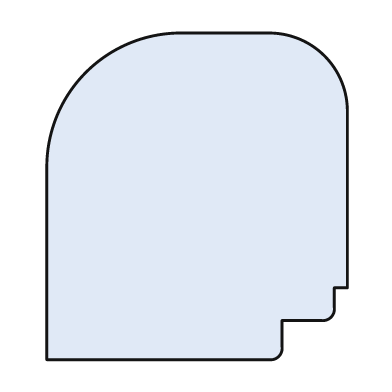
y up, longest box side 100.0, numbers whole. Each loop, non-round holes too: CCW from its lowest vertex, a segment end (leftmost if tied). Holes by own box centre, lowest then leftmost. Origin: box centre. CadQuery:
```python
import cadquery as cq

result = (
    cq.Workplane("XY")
    .moveTo(-46.0, -50.0)
    .lineTo(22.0, -50.0)
    .threePointArc((25.0, -49.0), (26.0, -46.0))
    .lineTo(26.0, -38.0)
    .lineTo(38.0, -38.0)
    .threePointArc((41.0, -37.0), (42.0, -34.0))
    .lineTo(42.0, -28.0)
    .lineTo(46.0, -28.0)
    .lineTo(46.0, 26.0)
    .threePointArc((39.0, 43.0), (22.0, 50.0))
    .lineTo(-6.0, 50.0)
    .threePointArc((-34.0, 38.0), (-46.0, 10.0))
    .close()
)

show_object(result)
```